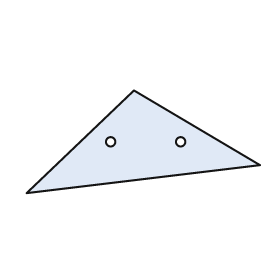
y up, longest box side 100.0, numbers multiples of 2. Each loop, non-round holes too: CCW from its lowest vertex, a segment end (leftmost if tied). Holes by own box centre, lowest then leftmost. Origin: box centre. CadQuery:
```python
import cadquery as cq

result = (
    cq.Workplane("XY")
    .moveTo(-50.0, -22.0)
    .lineTo(50.0, -10.0)
    .lineTo(-4.0, 22.0)
    .close()
    .moveTo(-14.0, 0.0)
    .circle(2.0)
    .moveTo(16.0, 0.0)
    .circle(2.0)
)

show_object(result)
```